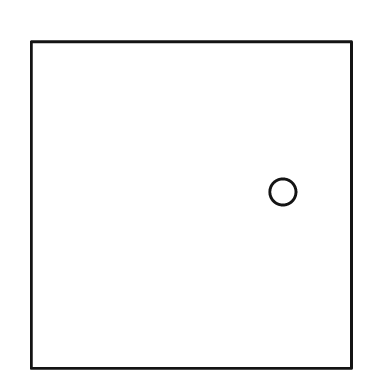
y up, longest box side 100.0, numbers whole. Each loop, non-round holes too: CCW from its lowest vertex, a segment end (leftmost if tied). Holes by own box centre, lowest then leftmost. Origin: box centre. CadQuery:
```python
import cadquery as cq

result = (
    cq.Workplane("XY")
    .moveTo(-49.0, -50.0)
    .lineTo(49.0, -50.0)
    .lineTo(49.0, 50.0)
    .lineTo(-49.0, 50.0)
    .close()
    .moveTo(28.0, 4.0)
    .circle(4.0)
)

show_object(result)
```